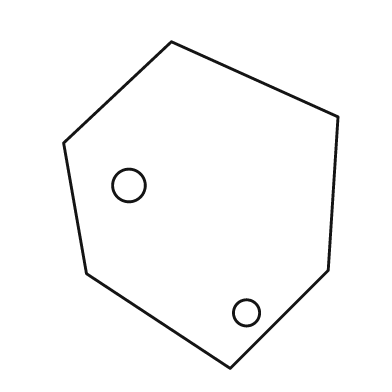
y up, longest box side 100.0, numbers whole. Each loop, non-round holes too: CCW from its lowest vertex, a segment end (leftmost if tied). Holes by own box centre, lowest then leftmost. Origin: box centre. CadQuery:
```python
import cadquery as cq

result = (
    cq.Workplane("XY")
    .moveTo(9.0, -50.0)
    .lineTo(39.0, -20.0)
    .lineTo(42.0, 27.0)
    .lineTo(-9.0, 50.0)
    .lineTo(-42.0, 19.0)
    .lineTo(-35.0, -21.0)
    .close()
    .moveTo(14.0, -33.0)
    .circle(4.0)
    .moveTo(-22.0, 6.0)
    .circle(5.0)
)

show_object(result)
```